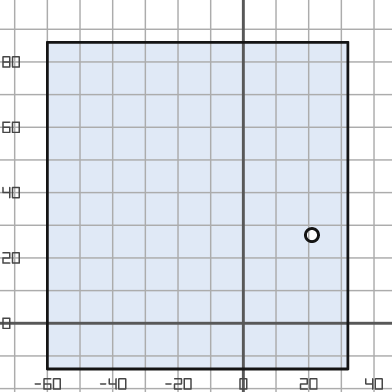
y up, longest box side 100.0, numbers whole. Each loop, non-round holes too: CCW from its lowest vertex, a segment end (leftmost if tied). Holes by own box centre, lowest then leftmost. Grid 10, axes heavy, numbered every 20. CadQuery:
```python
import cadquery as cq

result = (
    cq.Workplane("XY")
    .moveTo(-60.0, -14.0)
    .lineTo(32.0, -14.0)
    .lineTo(32.0, 86.0)
    .lineTo(-60.0, 86.0)
    .close()
    .moveTo(21.0, 27.0)
    .circle(2.0)
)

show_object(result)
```